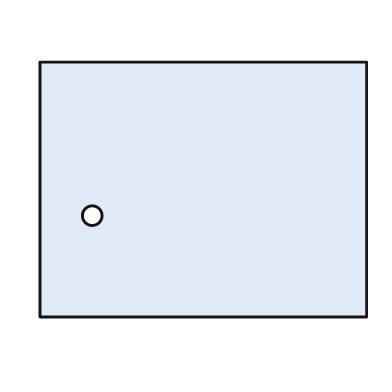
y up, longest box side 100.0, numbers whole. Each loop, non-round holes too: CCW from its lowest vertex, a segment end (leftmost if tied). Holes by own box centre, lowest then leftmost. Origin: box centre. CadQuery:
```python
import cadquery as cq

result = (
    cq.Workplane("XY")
    .moveTo(-50.0, -39.0)
    .lineTo(50.0, -39.0)
    .lineTo(50.0, 39.0)
    .lineTo(-50.0, 39.0)
    .close()
    .moveTo(-34.0, -8.0)
    .circle(3.0)
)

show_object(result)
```